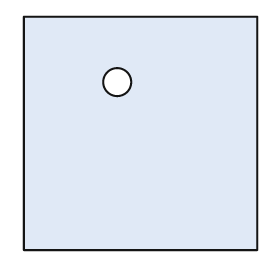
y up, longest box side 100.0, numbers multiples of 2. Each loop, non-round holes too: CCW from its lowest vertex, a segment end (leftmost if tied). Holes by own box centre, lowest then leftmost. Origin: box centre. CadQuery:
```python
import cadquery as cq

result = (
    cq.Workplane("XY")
    .moveTo(-50.0, -50.0)
    .lineTo(50.0, -50.0)
    .lineTo(50.0, 50.0)
    .lineTo(-50.0, 50.0)
    .close()
    .moveTo(-10.0, 22.0)
    .circle(6.0)
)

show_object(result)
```